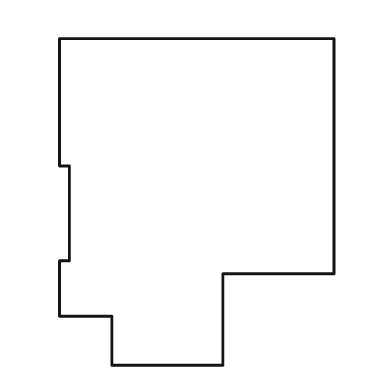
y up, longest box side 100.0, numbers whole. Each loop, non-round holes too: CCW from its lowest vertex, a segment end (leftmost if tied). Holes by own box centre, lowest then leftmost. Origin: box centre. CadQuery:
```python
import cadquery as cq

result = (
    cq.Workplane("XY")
    .moveTo(-26.0, -50.0)
    .lineTo(8.0, -50.0)
    .lineTo(8.0, -22.0)
    .lineTo(42.0, -22.0)
    .lineTo(42.0, 50.0)
    .lineTo(-42.0, 50.0)
    .lineTo(-42.0, 11.0)
    .lineTo(-39.0, 11.0)
    .lineTo(-39.0, -18.0)
    .lineTo(-42.0, -18.0)
    .lineTo(-42.0, -35.0)
    .lineTo(-26.0, -35.0)
    .close()
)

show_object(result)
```